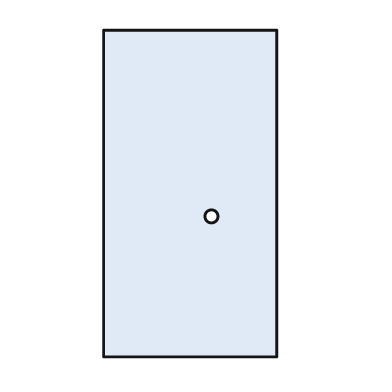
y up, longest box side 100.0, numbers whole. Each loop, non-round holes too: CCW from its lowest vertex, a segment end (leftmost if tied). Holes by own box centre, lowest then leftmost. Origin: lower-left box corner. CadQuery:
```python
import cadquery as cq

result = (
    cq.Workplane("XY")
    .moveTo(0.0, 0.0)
    .lineTo(53.0, 0.0)
    .lineTo(53.0, 100.0)
    .lineTo(0.0, 100.0)
    .close()
    .moveTo(33.0, 43.0)
    .circle(2.0)
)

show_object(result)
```